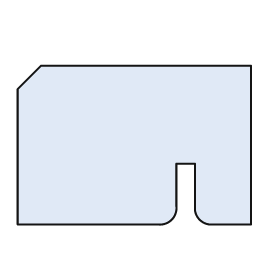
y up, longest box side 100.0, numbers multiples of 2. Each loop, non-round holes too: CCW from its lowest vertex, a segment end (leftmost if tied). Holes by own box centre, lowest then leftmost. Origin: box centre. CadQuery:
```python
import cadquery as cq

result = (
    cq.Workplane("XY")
    .moveTo(-50.0, -34.0)
    .lineTo(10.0, -34.0)
    .threePointArc((16.0, -32.0), (18.0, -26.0))
    .lineTo(18.0, -8.0)
    .lineTo(26.0, -8.0)
    .lineTo(26.0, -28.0)
    .threePointArc((28.0, -32.0), (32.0, -34.0))
    .lineTo(50.0, -34.0)
    .lineTo(50.0, 34.0)
    .lineTo(-40.0, 34.0)
    .lineTo(-50.0, 24.0)
    .close()
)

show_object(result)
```